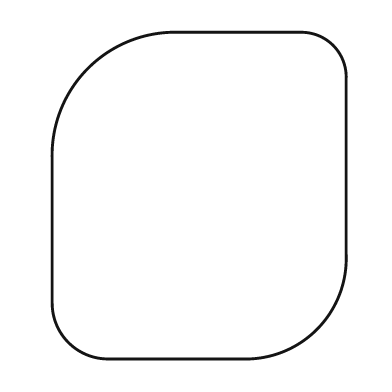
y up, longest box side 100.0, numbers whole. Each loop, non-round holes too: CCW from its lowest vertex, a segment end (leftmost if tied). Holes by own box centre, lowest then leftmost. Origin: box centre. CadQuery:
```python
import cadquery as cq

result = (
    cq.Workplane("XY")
    .moveTo(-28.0, -50.0)
    .lineTo(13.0, -50.0)
    .threePointArc((36.0, -41.0), (45.0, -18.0))
    .lineTo(45.0, 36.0)
    .threePointArc((41.0, 46.0), (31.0, 50.0))
    .lineTo(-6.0, 50.0)
    .threePointArc((-34.0, 39.0), (-45.0, 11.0))
    .lineTo(-45.0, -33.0)
    .threePointArc((-40.0, -45.0), (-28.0, -50.0))
    .close()
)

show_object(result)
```